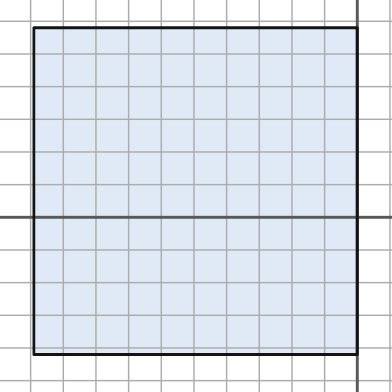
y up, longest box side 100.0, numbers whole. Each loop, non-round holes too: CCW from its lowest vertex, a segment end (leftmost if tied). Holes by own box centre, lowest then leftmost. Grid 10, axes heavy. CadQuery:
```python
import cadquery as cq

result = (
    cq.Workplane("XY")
    .moveTo(-99.0, -42.0)
    .lineTo(0.0, -42.0)
    .lineTo(0.0, 58.0)
    .lineTo(-99.0, 58.0)
    .close()
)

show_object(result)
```